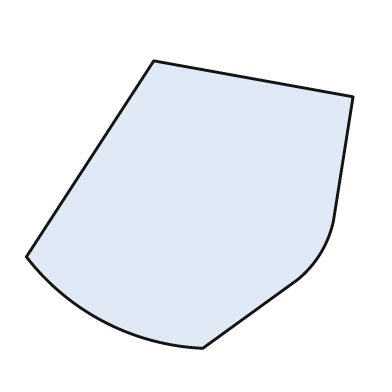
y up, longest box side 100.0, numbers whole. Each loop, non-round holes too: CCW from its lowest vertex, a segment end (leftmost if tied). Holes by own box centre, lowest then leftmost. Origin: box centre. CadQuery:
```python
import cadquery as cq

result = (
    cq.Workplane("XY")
    .moveTo(4.0, -44.0)
    .lineTo(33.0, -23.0)
    .threePointArc((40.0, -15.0), (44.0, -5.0))
    .lineTo(50.0, 33.0)
    .lineTo(-11.0, 44.0)
    .lineTo(-50.0, -16.0)
    .threePointArc((-26.0, -36.0), (4.0, -44.0))
    .close()
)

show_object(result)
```